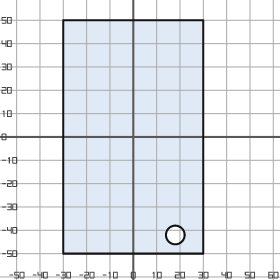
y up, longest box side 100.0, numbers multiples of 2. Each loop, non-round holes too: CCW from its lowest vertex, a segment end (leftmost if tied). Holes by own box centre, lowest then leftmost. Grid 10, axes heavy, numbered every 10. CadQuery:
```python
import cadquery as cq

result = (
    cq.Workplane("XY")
    .moveTo(-30.0, -50.0)
    .lineTo(30.0, -50.0)
    .lineTo(30.0, 50.0)
    .lineTo(-30.0, 50.0)
    .close()
    .moveTo(18.0, -42.0)
    .circle(4.0)
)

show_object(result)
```